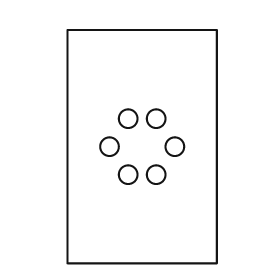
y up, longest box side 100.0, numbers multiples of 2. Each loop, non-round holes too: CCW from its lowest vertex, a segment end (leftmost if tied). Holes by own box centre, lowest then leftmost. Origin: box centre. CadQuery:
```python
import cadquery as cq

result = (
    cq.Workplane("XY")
    .moveTo(-32.0, -50.0)
    .lineTo(32.0, -50.0)
    .lineTo(32.0, 50.0)
    .lineTo(-32.0, 50.0)
    .close()
    .moveTo(-6.0, -12.0)
    .circle(4.0)
    .moveTo(6.0, -12.0)
    .circle(4.0)
    .moveTo(-14.0, 0.0)
    .circle(4.0)
    .moveTo(14.0, 0.0)
    .circle(4.0)
    .moveTo(-6.0, 12.0)
    .circle(4.0)
    .moveTo(6.0, 12.0)
    .circle(4.0)
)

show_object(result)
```